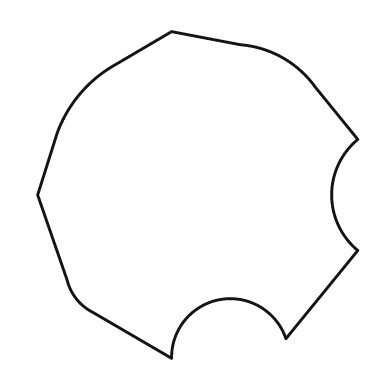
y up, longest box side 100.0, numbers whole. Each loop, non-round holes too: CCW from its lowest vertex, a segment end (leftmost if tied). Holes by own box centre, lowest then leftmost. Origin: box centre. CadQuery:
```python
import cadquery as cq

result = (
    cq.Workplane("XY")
    .moveTo(-8.0, -50.0)
    .threePointArc((7.0, -32.0), (27.0, -44.0))
    .lineTo(49.0, -17.0)
    .threePointArc((41.0, 0.0), (49.0, 17.0))
    .lineTo(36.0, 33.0)
    .threePointArc((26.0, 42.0), (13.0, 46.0))
    .lineTo(-8.0, 50.0)
    .lineTo(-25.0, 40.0)
    .threePointArc((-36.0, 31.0), (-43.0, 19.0))
    .lineTo(-49.0, 0.0)
    .lineTo(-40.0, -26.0)
    .threePointArc((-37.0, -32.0), (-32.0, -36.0))
    .close()
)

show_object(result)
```